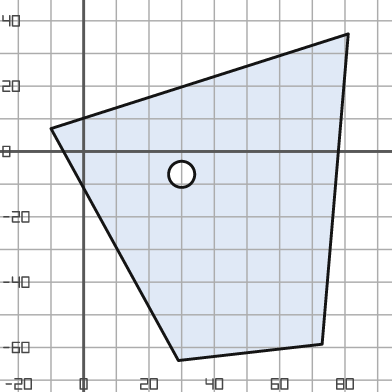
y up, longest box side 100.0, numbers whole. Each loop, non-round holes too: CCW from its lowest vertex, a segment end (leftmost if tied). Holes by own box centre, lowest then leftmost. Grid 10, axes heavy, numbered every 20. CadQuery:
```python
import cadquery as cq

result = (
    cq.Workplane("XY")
    .moveTo(29.0, -64.0)
    .lineTo(73.0, -59.0)
    .lineTo(81.0, 36.0)
    .lineTo(-10.0, 7.0)
    .close()
    .moveTo(30.0, -7.0)
    .circle(4.0)
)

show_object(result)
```